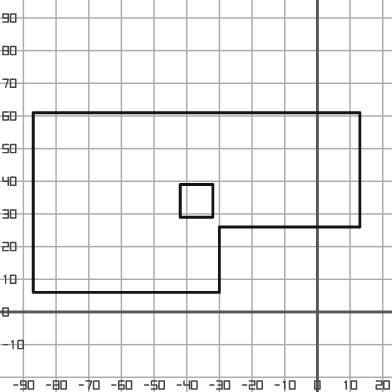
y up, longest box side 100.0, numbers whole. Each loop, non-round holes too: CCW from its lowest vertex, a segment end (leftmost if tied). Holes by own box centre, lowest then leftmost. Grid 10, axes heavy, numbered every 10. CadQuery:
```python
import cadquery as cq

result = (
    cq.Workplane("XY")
    .moveTo(-87.0, 6.0)
    .lineTo(-30.0, 6.0)
    .lineTo(-30.0, 26.0)
    .lineTo(13.0, 26.0)
    .lineTo(13.0, 61.0)
    .lineTo(-87.0, 61.0)
    .close()
    .moveTo(-42.0, 29.0)
    .lineTo(-32.0, 29.0)
    .lineTo(-32.0, 39.0)
    .lineTo(-42.0, 39.0)
    .close()
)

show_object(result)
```